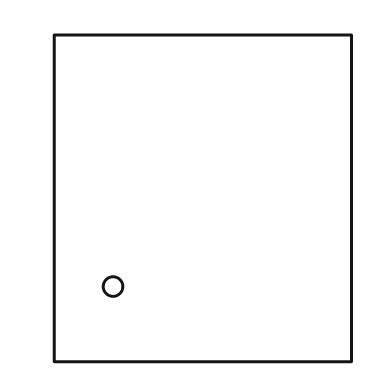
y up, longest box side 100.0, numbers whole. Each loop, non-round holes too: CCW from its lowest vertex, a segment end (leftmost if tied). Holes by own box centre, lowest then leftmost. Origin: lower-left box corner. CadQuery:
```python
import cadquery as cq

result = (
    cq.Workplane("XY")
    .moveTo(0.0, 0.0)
    .lineTo(91.0, 0.0)
    .lineTo(91.0, 100.0)
    .lineTo(0.0, 100.0)
    .close()
    .moveTo(18.0, 23.0)
    .circle(3.0)
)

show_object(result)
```